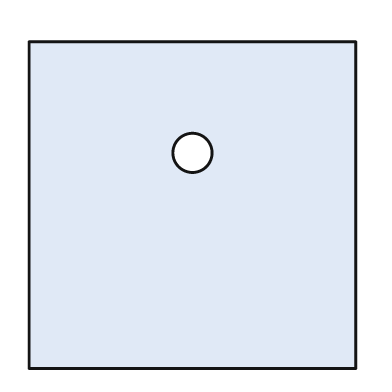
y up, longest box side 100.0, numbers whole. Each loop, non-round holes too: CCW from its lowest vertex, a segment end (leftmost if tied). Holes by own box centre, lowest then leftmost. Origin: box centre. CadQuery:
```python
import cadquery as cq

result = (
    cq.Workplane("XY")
    .moveTo(-50.0, -50.0)
    .lineTo(50.0, -50.0)
    .lineTo(50.0, 50.0)
    .lineTo(-50.0, 50.0)
    .close()
    .moveTo(0.0, 16.0)
    .circle(6.0)
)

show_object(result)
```